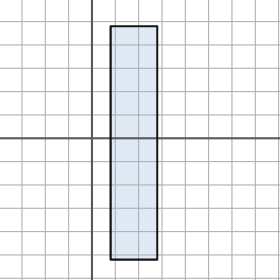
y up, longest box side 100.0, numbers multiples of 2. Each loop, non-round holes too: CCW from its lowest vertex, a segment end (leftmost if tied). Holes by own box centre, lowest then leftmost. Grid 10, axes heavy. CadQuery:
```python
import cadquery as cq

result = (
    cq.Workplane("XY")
    .moveTo(8.0, -52.0)
    .lineTo(28.0, -52.0)
    .lineTo(28.0, 48.0)
    .lineTo(8.0, 48.0)
    .close()
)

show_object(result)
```